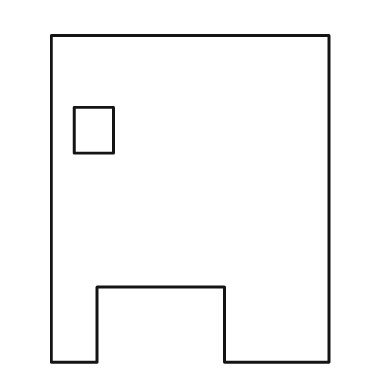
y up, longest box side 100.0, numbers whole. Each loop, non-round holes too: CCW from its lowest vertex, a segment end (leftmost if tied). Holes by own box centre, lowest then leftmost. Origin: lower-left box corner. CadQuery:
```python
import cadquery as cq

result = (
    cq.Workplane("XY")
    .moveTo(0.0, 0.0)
    .lineTo(14.0, 0.0)
    .lineTo(14.0, 23.0)
    .lineTo(53.0, 23.0)
    .lineTo(53.0, 0.0)
    .lineTo(85.0, 0.0)
    .lineTo(85.0, 100.0)
    .lineTo(0.0, 100.0)
    .close()
    .moveTo(7.0, 64.0)
    .lineTo(19.0, 64.0)
    .lineTo(19.0, 78.0)
    .lineTo(7.0, 78.0)
    .close()
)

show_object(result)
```